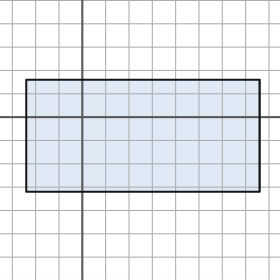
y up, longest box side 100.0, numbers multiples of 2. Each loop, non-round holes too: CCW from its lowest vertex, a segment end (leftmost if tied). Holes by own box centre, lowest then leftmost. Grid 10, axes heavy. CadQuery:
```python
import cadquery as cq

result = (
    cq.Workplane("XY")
    .moveTo(-24.0, -32.0)
    .lineTo(76.0, -32.0)
    .lineTo(76.0, 16.0)
    .lineTo(-24.0, 16.0)
    .close()
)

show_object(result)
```